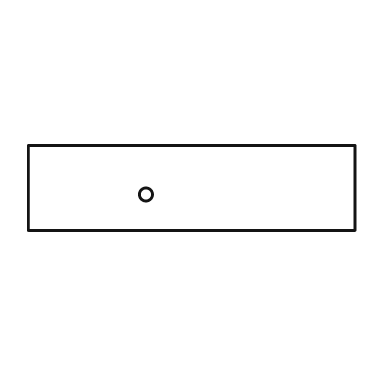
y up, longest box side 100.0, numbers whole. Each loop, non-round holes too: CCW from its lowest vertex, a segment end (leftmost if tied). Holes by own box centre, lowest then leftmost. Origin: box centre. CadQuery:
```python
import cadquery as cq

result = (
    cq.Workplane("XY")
    .moveTo(-50.0, -13.0)
    .lineTo(50.0, -13.0)
    .lineTo(50.0, 13.0)
    .lineTo(-50.0, 13.0)
    .close()
    .moveTo(-14.0, -2.0)
    .circle(2.0)
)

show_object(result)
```